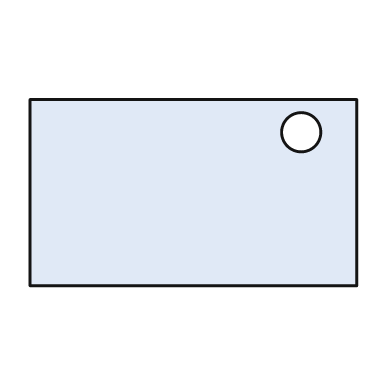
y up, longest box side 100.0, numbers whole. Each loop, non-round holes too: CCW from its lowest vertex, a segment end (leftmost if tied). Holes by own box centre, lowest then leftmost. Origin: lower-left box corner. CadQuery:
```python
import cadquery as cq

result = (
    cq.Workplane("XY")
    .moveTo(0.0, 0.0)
    .lineTo(100.0, 0.0)
    .lineTo(100.0, 57.0)
    .lineTo(0.0, 57.0)
    .close()
    .moveTo(83.0, 47.0)
    .circle(6.0)
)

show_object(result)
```